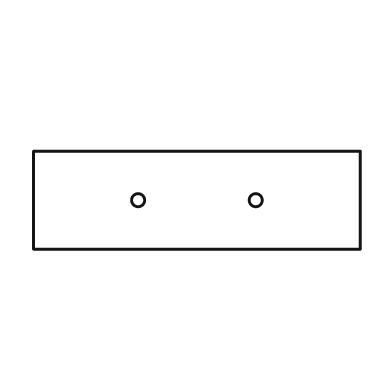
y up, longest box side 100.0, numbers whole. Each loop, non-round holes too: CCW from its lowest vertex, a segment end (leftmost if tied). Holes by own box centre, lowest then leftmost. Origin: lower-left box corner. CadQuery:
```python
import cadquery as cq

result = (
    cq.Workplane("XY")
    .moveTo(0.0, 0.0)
    .lineTo(100.0, 0.0)
    .lineTo(100.0, 30.0)
    .lineTo(0.0, 30.0)
    .close()
    .moveTo(32.0, 15.0)
    .circle(2.0)
    .moveTo(68.0, 15.0)
    .circle(2.0)
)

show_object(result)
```